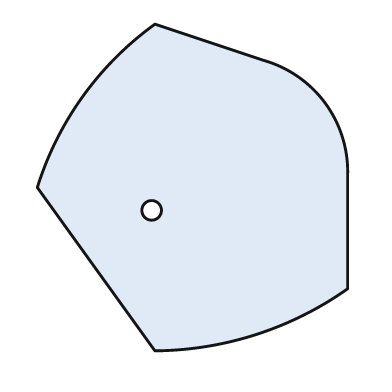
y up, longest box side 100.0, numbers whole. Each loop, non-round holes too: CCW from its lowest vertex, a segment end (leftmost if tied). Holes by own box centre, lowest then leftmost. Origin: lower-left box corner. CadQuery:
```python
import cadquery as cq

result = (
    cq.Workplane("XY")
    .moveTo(36.0, 0.0)
    .threePointArc((67.0, 5.0), (95.0, 19.0))
    .lineTo(95.0, 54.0)
    .threePointArc((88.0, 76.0), (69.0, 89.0))
    .lineTo(36.0, 100.0)
    .threePointArc((14.0, 78.0), (0.0, 50.0))
    .close()
    .moveTo(35.0, 43.0)
    .circle(3.0)
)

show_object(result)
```